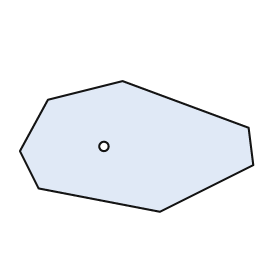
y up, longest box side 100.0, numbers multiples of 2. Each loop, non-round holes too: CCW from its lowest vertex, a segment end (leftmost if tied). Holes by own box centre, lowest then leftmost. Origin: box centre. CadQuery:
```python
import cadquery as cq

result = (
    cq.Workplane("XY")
    .moveTo(10.0, -28.0)
    .lineTo(50.0, -8.0)
    .lineTo(48.0, 8.0)
    .lineTo(-6.0, 28.0)
    .lineTo(-38.0, 20.0)
    .lineTo(-50.0, -2.0)
    .lineTo(-42.0, -18.0)
    .close()
    .moveTo(-14.0, 0.0)
    .circle(2.0)
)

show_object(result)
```